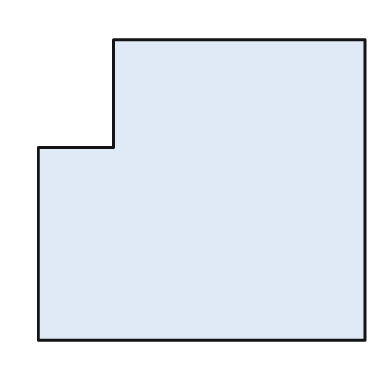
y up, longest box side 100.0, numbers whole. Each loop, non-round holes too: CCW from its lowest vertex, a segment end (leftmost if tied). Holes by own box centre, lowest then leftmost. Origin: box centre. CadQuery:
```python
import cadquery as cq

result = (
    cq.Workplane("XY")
    .moveTo(-50.0, -46.0)
    .lineTo(50.0, -46.0)
    .lineTo(50.0, 46.0)
    .lineTo(-27.0, 46.0)
    .lineTo(-27.0, 13.0)
    .lineTo(-50.0, 13.0)
    .close()
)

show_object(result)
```